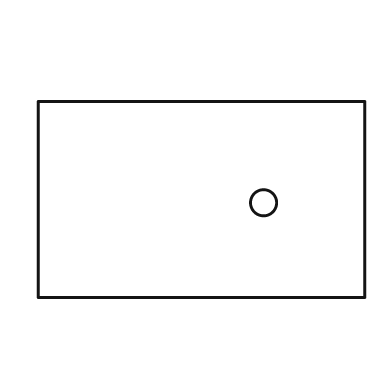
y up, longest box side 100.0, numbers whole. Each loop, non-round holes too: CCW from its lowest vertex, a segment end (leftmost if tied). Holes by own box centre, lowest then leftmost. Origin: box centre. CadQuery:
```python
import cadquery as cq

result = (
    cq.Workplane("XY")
    .moveTo(-50.0, -30.0)
    .lineTo(50.0, -30.0)
    .lineTo(50.0, 30.0)
    .lineTo(-50.0, 30.0)
    .close()
    .moveTo(19.0, -1.0)
    .circle(4.0)
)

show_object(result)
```